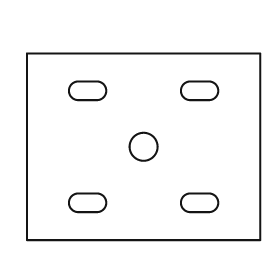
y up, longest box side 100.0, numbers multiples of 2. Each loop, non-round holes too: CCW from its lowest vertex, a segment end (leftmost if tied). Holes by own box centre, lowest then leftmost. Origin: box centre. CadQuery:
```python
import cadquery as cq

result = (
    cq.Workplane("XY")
    .moveTo(-50.0, -40.0)
    .lineTo(50.0, -40.0)
    .lineTo(50.0, 40.0)
    .lineTo(-50.0, 40.0)
    .close()
    .moveTo(-28.0, -28.0)
    .lineTo(-20.0, -28.0)
    .threePointArc((-16.0, -24.0), (-20.0, -20.0))
    .lineTo(-28.0, -20.0)
    .threePointArc((-32.0, -24.0), (-28.0, -28.0))
    .close()
    .moveTo(20.0, -28.0)
    .lineTo(28.0, -28.0)
    .threePointArc((32.0, -24.0), (28.0, -20.0))
    .lineTo(20.0, -20.0)
    .threePointArc((16.0, -24.0), (20.0, -28.0))
    .close()
    .moveTo(0.0, 0.0)
    .circle(6.0)
    .moveTo(-28.0, 20.0)
    .lineTo(-20.0, 20.0)
    .threePointArc((-16.0, 24.0), (-20.0, 28.0))
    .lineTo(-28.0, 28.0)
    .threePointArc((-32.0, 24.0), (-28.0, 20.0))
    .close()
    .moveTo(20.0, 20.0)
    .lineTo(28.0, 20.0)
    .threePointArc((32.0, 24.0), (28.0, 28.0))
    .lineTo(20.0, 28.0)
    .threePointArc((16.0, 24.0), (20.0, 20.0))
    .close()
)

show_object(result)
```